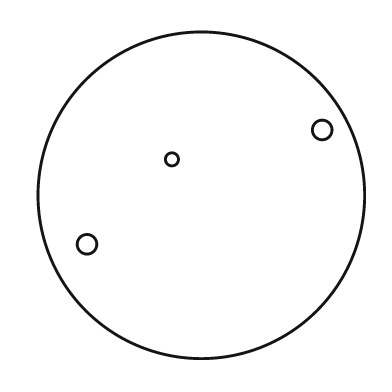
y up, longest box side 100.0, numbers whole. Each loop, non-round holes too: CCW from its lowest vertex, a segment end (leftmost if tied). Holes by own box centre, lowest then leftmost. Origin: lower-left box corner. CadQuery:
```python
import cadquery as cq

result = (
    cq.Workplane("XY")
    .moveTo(50.0, 50.0)
    .circle(50.0)
    .moveTo(15.0, 35.0)
    .circle(3.0)
    .moveTo(41.0, 61.0)
    .circle(2.0)
    .moveTo(87.0, 70.0)
    .circle(3.0)
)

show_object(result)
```